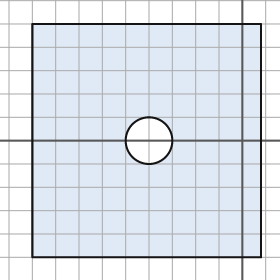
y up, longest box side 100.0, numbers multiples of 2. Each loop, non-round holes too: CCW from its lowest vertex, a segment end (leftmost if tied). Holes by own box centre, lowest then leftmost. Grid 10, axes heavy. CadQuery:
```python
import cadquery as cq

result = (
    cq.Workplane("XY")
    .moveTo(-90.0, -50.0)
    .lineTo(8.0, -50.0)
    .lineTo(8.0, 50.0)
    .lineTo(-90.0, 50.0)
    .close()
    .moveTo(-40.0, 0.0)
    .circle(10.0)
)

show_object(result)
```